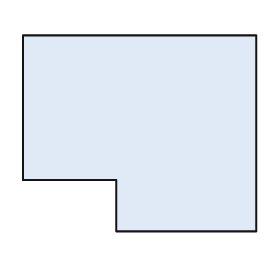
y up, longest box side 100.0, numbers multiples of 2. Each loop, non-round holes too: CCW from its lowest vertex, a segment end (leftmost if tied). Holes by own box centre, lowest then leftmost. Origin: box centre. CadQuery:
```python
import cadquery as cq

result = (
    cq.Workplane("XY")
    .moveTo(-10.0, -42.0)
    .lineTo(50.0, -42.0)
    .lineTo(50.0, 42.0)
    .lineTo(-50.0, 42.0)
    .lineTo(-50.0, -20.0)
    .lineTo(-10.0, -20.0)
    .close()
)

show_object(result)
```